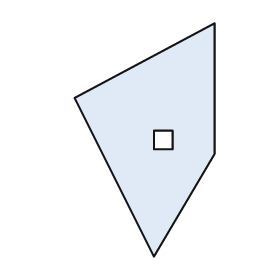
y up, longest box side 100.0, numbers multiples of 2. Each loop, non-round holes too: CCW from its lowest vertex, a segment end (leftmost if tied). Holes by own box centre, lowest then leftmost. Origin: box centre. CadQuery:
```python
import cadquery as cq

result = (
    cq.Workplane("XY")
    .moveTo(4.0, -50.0)
    .lineTo(30.0, -6.0)
    .lineTo(30.0, 50.0)
    .lineTo(-30.0, 18.0)
    .close()
    .moveTo(4.0, -4.0)
    .lineTo(12.0, -4.0)
    .lineTo(12.0, 4.0)
    .lineTo(4.0, 4.0)
    .close()
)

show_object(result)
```